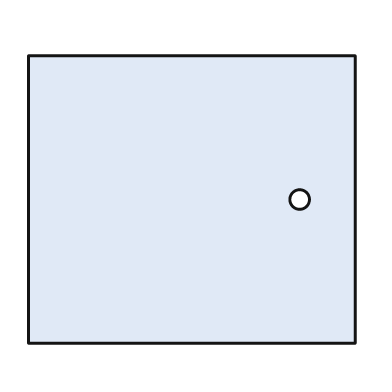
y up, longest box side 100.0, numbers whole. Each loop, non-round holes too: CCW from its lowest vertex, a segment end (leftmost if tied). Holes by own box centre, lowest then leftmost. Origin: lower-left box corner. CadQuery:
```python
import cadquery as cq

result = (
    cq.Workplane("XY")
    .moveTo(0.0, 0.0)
    .lineTo(100.0, 0.0)
    .lineTo(100.0, 88.0)
    .lineTo(0.0, 88.0)
    .close()
    .moveTo(83.0, 44.0)
    .circle(3.0)
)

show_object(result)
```